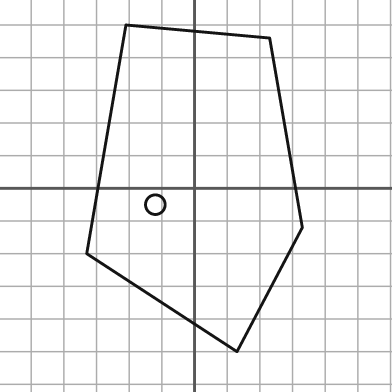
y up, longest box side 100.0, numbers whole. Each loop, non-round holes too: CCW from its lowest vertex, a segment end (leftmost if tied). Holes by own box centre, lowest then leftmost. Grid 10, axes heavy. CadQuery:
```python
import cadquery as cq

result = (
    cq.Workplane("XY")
    .moveTo(13.0, -50.0)
    .lineTo(33.0, -12.0)
    .lineTo(23.0, 46.0)
    .lineTo(-21.0, 50.0)
    .lineTo(-33.0, -20.0)
    .close()
    .moveTo(-12.0, -5.0)
    .circle(3.0)
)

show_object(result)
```